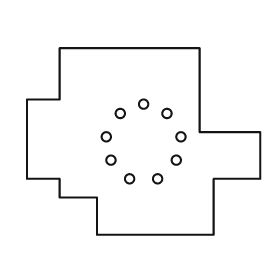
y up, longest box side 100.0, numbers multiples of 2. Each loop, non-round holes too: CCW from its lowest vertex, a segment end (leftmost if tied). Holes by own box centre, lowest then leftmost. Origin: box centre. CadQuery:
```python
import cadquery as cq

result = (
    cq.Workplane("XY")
    .moveTo(-20.0, -40.0)
    .lineTo(30.0, -40.0)
    .lineTo(30.0, -16.0)
    .lineTo(50.0, -16.0)
    .lineTo(50.0, 4.0)
    .lineTo(24.0, 4.0)
    .lineTo(24.0, 40.0)
    .lineTo(-36.0, 40.0)
    .lineTo(-36.0, 18.0)
    .lineTo(-50.0, 18.0)
    .lineTo(-50.0, -16.0)
    .lineTo(-36.0, -16.0)
    .lineTo(-36.0, -24.0)
    .lineTo(-20.0, -24.0)
    .close()
    .moveTo(-6.0, -16.0)
    .circle(2.0)
    .moveTo(6.0, -16.0)
    .circle(2.0)
    .moveTo(-14.0, -8.0)
    .circle(2.0)
    .moveTo(14.0, -8.0)
    .circle(2.0)
    .moveTo(-16.0, 2.0)
    .circle(2.0)
    .moveTo(16.0, 2.0)
    .circle(2.0)
    .moveTo(-10.0, 12.0)
    .circle(2.0)
    .moveTo(10.0, 12.0)
    .circle(2.0)
    .moveTo(0.0, 16.0)
    .circle(2.0)
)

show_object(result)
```